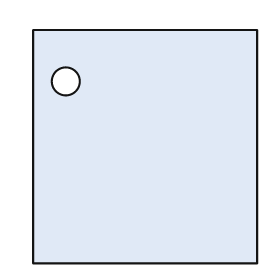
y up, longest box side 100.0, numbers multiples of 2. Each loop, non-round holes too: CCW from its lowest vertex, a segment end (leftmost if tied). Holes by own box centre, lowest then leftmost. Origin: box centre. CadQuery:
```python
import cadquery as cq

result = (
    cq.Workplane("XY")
    .moveTo(-48.0, -50.0)
    .lineTo(48.0, -50.0)
    .lineTo(48.0, 50.0)
    .lineTo(-48.0, 50.0)
    .close()
    .moveTo(-34.0, 28.0)
    .circle(6.0)
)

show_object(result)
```